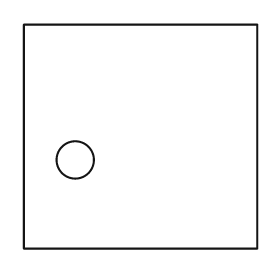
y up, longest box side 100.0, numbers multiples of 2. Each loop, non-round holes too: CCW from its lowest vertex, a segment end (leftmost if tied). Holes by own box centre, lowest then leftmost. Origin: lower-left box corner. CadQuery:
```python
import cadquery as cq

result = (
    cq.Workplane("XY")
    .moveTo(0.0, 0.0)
    .lineTo(100.0, 0.0)
    .lineTo(100.0, 96.0)
    .lineTo(0.0, 96.0)
    .close()
    .moveTo(22.0, 38.0)
    .circle(8.0)
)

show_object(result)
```